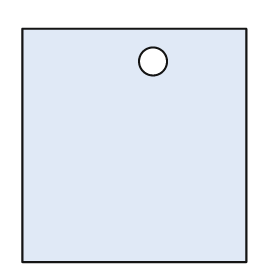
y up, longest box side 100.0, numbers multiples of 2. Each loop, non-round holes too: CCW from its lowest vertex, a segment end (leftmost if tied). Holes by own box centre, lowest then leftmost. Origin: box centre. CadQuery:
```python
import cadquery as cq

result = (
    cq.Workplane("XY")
    .moveTo(-48.0, -50.0)
    .lineTo(48.0, -50.0)
    .lineTo(48.0, 50.0)
    .lineTo(-48.0, 50.0)
    .close()
    .moveTo(8.0, 36.0)
    .circle(6.0)
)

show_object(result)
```